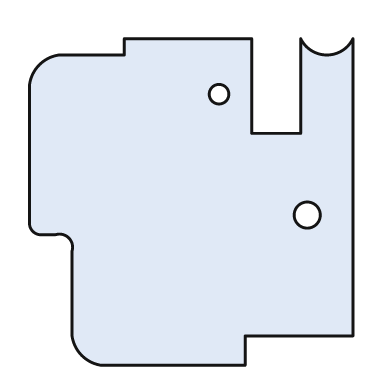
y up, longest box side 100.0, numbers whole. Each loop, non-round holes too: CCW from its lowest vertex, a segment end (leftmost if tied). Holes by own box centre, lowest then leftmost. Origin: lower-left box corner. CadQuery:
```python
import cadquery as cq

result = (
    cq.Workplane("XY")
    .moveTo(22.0, 0.0)
    .lineTo(66.0, 0.0)
    .lineTo(66.0, 9.0)
    .lineTo(99.0, 9.0)
    .lineTo(99.0, 100.0)
    .threePointArc((91.0, 95.0), (83.0, 100.0))
    .lineTo(83.0, 71.0)
    .lineTo(68.0, 71.0)
    .lineTo(68.0, 100.0)
    .lineTo(29.0, 100.0)
    .lineTo(29.0, 95.0)
    .lineTo(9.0, 95.0)
    .threePointArc((3.0, 92.0), (0.0, 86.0))
    .lineTo(0.0, 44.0)
    .threePointArc((1.0, 41.0), (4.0, 40.0))
    .lineTo(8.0, 40.0)
    .threePointArc((12.0, 39.0), (13.0, 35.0))
    .lineTo(13.0, 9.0)
    .threePointArc((16.0, 3.0), (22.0, 0.0))
    .close()
    .moveTo(85.0, 46.0)
    .circle(4.0)
    .moveTo(58.0, 83.0)
    .circle(3.0)
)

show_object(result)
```